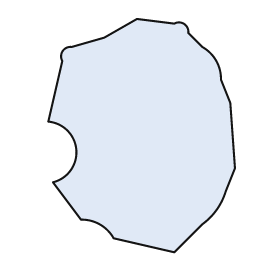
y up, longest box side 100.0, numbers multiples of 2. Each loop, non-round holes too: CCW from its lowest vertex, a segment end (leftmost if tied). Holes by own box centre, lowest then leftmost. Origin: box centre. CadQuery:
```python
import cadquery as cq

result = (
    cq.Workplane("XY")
    .moveTo(14.0, -50.0)
    .lineTo(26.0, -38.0)
    .threePointArc((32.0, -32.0), (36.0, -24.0))
    .lineTo(40.0, -14.0)
    .lineTo(38.0, 14.0)
    .lineTo(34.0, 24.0)
    .threePointArc((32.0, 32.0), (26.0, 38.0))
    .lineTo(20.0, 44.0)
    .threePointArc((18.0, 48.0), (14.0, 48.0))
    .lineTo(-2.0, 50.0)
    .lineTo(-16.0, 42.0)
    .lineTo(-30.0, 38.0)
    .threePointArc((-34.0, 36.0), (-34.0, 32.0))
    .lineTo(-40.0, 6.0)
    .threePointArc((-28.0, -6.0), (-38.0, -20.0))
    .lineTo(-26.0, -36.0)
    .threePointArc((-18.0, -38.0), (-12.0, -44.0))
    .close()
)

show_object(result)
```